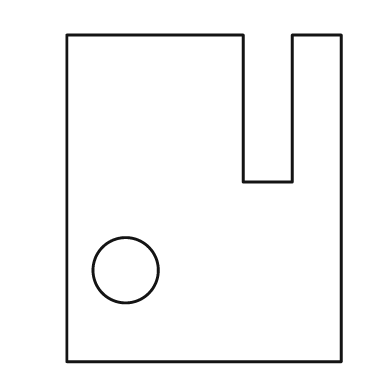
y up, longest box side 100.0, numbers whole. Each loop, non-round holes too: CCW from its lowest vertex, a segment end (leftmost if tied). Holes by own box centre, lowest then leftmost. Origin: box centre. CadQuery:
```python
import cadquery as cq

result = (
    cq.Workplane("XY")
    .moveTo(-42.0, -50.0)
    .lineTo(42.0, -50.0)
    .lineTo(42.0, 50.0)
    .lineTo(27.0, 50.0)
    .lineTo(27.0, 5.0)
    .lineTo(12.0, 5.0)
    .lineTo(12.0, 50.0)
    .lineTo(-42.0, 50.0)
    .close()
    .moveTo(-24.0, -22.0)
    .circle(10.0)
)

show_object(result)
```